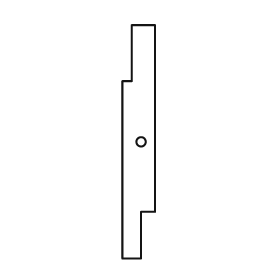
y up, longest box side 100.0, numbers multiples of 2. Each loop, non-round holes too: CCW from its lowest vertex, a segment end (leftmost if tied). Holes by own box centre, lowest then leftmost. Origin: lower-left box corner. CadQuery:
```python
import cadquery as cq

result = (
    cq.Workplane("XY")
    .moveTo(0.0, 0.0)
    .lineTo(8.0, 0.0)
    .lineTo(8.0, 20.0)
    .lineTo(14.0, 20.0)
    .lineTo(14.0, 100.0)
    .lineTo(4.0, 100.0)
    .lineTo(4.0, 76.0)
    .lineTo(0.0, 76.0)
    .close()
    .moveTo(8.0, 50.0)
    .circle(2.0)
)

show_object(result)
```